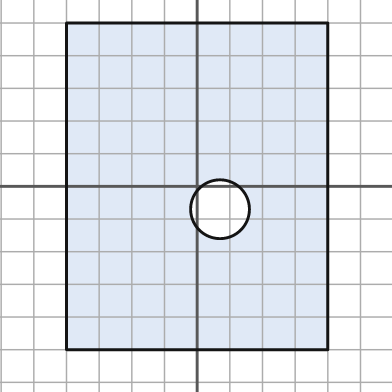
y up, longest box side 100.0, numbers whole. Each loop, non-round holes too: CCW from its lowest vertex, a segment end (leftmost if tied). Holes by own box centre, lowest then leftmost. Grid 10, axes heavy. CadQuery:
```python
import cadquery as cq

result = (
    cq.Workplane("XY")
    .moveTo(-40.0, -50.0)
    .lineTo(40.0, -50.0)
    .lineTo(40.0, 50.0)
    .lineTo(-40.0, 50.0)
    .close()
    .moveTo(7.0, -7.0)
    .circle(9.0)
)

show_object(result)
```